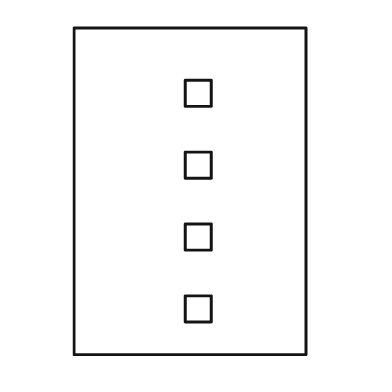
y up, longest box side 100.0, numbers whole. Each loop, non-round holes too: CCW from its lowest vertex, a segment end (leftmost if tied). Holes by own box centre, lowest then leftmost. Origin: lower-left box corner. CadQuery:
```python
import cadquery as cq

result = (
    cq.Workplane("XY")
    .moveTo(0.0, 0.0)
    .lineTo(71.0, 0.0)
    .lineTo(71.0, 100.0)
    .lineTo(0.0, 100.0)
    .close()
    .moveTo(34.0, 10.0)
    .lineTo(42.0, 10.0)
    .lineTo(42.0, 18.0)
    .lineTo(34.0, 18.0)
    .close()
    .moveTo(34.0, 32.0)
    .lineTo(42.0, 32.0)
    .lineTo(42.0, 40.0)
    .lineTo(34.0, 40.0)
    .close()
    .moveTo(34.0, 54.0)
    .lineTo(42.0, 54.0)
    .lineTo(42.0, 62.0)
    .lineTo(34.0, 62.0)
    .close()
    .moveTo(34.0, 76.0)
    .lineTo(42.0, 76.0)
    .lineTo(42.0, 84.0)
    .lineTo(34.0, 84.0)
    .close()
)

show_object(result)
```